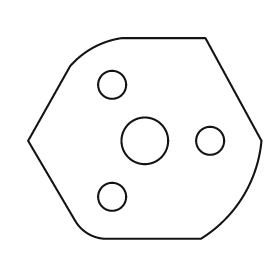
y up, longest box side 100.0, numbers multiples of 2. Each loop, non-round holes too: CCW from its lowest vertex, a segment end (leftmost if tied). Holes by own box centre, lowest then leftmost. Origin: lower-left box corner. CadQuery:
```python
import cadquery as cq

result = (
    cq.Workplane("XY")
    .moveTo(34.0, 0.0)
    .lineTo(74.0, 0.0)
    .threePointArc((92.0, 18.0), (100.0, 42.0))
    .lineTo(76.0, 86.0)
    .lineTo(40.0, 86.0)
    .threePointArc((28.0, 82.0), (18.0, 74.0))
    .lineTo(0.0, 42.0)
    .lineTo(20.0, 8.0)
    .threePointArc((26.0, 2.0), (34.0, 0.0))
    .close()
    .moveTo(36.0, 18.0)
    .circle(6.0)
    .moveTo(50.0, 42.0)
    .circle(10.0)
    .moveTo(78.0, 42.0)
    .circle(6.0)
    .moveTo(36.0, 66.0)
    .circle(6.0)
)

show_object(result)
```